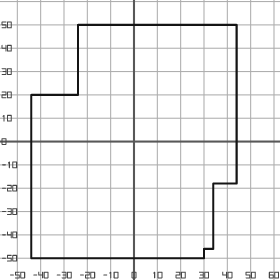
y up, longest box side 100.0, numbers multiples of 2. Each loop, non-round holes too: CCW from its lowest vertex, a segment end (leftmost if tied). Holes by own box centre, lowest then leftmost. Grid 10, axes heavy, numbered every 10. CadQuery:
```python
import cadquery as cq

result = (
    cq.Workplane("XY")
    .moveTo(-44.0, -50.0)
    .lineTo(30.0, -50.0)
    .lineTo(30.0, -46.0)
    .lineTo(34.0, -46.0)
    .lineTo(34.0, -18.0)
    .lineTo(44.0, -18.0)
    .lineTo(44.0, 50.0)
    .lineTo(-24.0, 50.0)
    .lineTo(-24.0, 20.0)
    .lineTo(-44.0, 20.0)
    .close()
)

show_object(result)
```